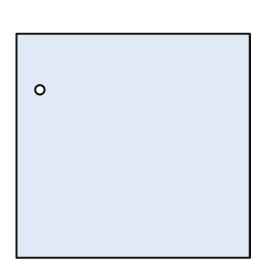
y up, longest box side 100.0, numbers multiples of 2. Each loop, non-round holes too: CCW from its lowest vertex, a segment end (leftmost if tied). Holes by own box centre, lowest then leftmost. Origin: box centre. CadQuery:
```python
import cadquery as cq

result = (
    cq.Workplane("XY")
    .moveTo(-50.0, -48.0)
    .lineTo(50.0, -48.0)
    .lineTo(50.0, 48.0)
    .lineTo(-50.0, 48.0)
    .close()
    .moveTo(-40.0, 24.0)
    .circle(2.0)
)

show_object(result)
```